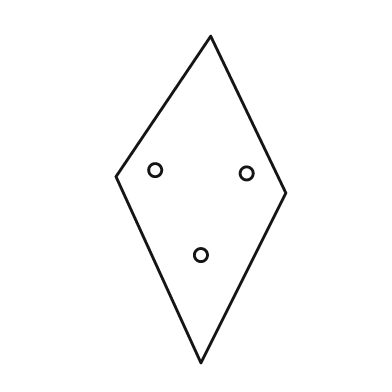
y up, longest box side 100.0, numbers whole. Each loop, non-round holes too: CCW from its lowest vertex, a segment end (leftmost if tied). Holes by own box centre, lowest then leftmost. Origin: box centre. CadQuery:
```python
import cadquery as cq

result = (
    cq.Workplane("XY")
    .moveTo(0.0, -50.0)
    .lineTo(26.0, 2.0)
    .lineTo(3.0, 50.0)
    .lineTo(-26.0, 7.0)
    .close()
    .moveTo(0.0, -17.0)
    .circle(2.0)
    .moveTo(14.0, 8.0)
    .circle(2.0)
    .moveTo(-14.0, 9.0)
    .circle(2.0)
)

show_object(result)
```